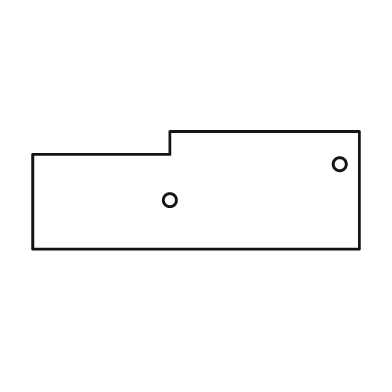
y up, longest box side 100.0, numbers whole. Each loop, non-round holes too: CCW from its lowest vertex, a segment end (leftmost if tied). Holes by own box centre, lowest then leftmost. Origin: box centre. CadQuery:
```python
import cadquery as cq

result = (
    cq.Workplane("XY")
    .moveTo(-50.0, -18.0)
    .lineTo(50.0, -18.0)
    .lineTo(50.0, 18.0)
    .lineTo(-8.0, 18.0)
    .lineTo(-8.0, 11.0)
    .lineTo(-50.0, 11.0)
    .close()
    .moveTo(-8.0, -3.0)
    .circle(2.0)
    .moveTo(44.0, 8.0)
    .circle(2.0)
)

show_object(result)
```